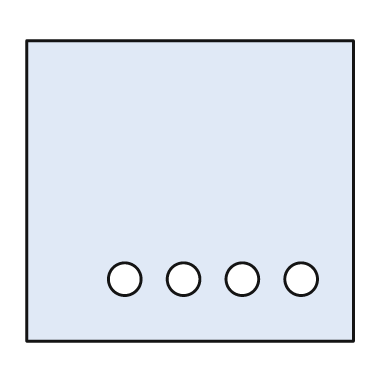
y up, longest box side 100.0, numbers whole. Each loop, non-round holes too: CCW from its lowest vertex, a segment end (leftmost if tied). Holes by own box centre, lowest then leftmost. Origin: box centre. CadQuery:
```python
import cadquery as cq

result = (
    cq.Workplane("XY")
    .moveTo(-50.0, -46.0)
    .lineTo(50.0, -46.0)
    .lineTo(50.0, 46.0)
    .lineTo(-50.0, 46.0)
    .close()
    .moveTo(-20.0, -27.0)
    .circle(5.0)
    .moveTo(-2.0, -27.0)
    .circle(5.0)
    .moveTo(16.0, -27.0)
    .circle(5.0)
    .moveTo(34.0, -27.0)
    .circle(5.0)
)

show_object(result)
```